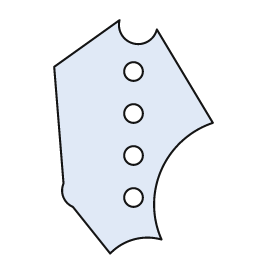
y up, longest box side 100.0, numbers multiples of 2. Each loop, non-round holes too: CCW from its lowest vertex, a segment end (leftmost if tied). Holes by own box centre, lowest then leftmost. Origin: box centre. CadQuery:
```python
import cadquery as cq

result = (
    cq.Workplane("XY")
    .moveTo(-10.0, -50.0)
    .threePointArc((0.0, -44.0), (12.0, -44.0))
    .threePointArc((12.0, -14.0), (34.0, 6.0))
    .lineTo(10.0, 46.0)
    .threePointArc((0.0, 40.0), (-6.0, 50.0))
    .lineTo(-34.0, 30.0)
    .lineTo(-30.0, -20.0)
    .threePointArc((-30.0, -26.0), (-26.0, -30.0))
    .close()
    .moveTo(0.0, -26.0)
    .circle(4.0)
    .moveTo(0.0, -8.0)
    .circle(4.0)
    .moveTo(0.0, 10.0)
    .circle(4.0)
    .moveTo(0.0, 28.0)
    .circle(4.0)
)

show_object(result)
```